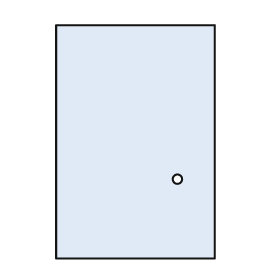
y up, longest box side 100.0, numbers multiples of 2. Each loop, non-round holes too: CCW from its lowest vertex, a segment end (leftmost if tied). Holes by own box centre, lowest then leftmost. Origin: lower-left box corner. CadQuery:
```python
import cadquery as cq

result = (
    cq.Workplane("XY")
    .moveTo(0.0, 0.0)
    .lineTo(68.0, 0.0)
    .lineTo(68.0, 100.0)
    .lineTo(0.0, 100.0)
    .close()
    .moveTo(52.0, 34.0)
    .circle(2.0)
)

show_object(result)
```